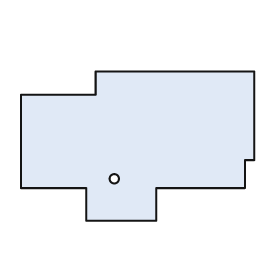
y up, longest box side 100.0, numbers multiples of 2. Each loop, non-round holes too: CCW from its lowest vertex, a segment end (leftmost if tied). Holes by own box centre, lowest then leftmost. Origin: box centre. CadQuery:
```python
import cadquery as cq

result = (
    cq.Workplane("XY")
    .moveTo(-22.0, -32.0)
    .lineTo(8.0, -32.0)
    .lineTo(8.0, -18.0)
    .lineTo(46.0, -18.0)
    .lineTo(46.0, -6.0)
    .lineTo(50.0, -6.0)
    .lineTo(50.0, 32.0)
    .lineTo(-18.0, 32.0)
    .lineTo(-18.0, 22.0)
    .lineTo(-50.0, 22.0)
    .lineTo(-50.0, -18.0)
    .lineTo(-22.0, -18.0)
    .close()
    .moveTo(-10.0, -14.0)
    .circle(2.0)
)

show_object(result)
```